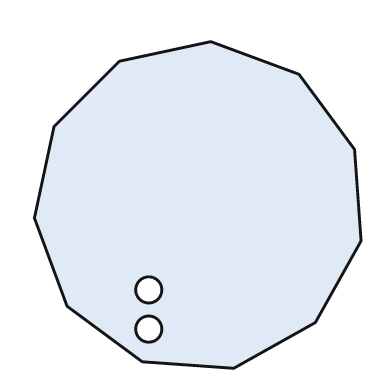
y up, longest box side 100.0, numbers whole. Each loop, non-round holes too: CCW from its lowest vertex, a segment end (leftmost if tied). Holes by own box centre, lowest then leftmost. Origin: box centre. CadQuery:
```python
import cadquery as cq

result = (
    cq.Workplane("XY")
    .moveTo(11.0, -50.0)
    .lineTo(36.0, -36.0)
    .lineTo(50.0, -11.0)
    .lineTo(48.0, 17.0)
    .lineTo(31.0, 40.0)
    .lineTo(4.0, 50.0)
    .lineTo(-24.0, 44.0)
    .lineTo(-44.0, 24.0)
    .lineTo(-50.0, -4.0)
    .lineTo(-40.0, -31.0)
    .lineTo(-17.0, -48.0)
    .close()
    .moveTo(-15.0, -38.0)
    .circle(4.0)
    .moveTo(-15.0, -26.0)
    .circle(4.0)
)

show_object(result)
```